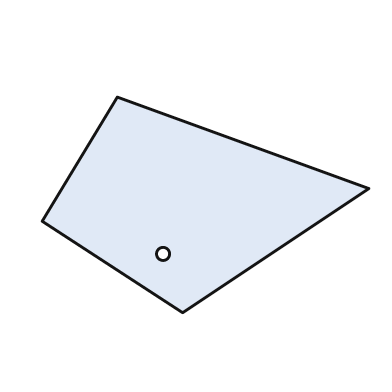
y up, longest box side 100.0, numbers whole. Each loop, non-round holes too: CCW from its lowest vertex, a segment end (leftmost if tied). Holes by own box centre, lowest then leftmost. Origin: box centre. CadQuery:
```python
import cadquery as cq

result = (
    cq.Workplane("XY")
    .moveTo(-7.0, -33.0)
    .lineTo(50.0, 5.0)
    .lineTo(-27.0, 33.0)
    .lineTo(-50.0, -5.0)
    .close()
    .moveTo(-13.0, -15.0)
    .circle(2.0)
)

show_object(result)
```